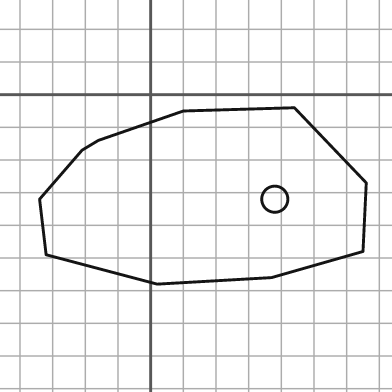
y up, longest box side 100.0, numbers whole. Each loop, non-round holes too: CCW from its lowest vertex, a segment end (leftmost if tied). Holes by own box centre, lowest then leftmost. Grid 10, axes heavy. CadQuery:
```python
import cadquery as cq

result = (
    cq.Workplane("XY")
    .moveTo(2.0, -58.0)
    .lineTo(37.0, -56.0)
    .lineTo(65.0, -48.0)
    .lineTo(66.0, -27.0)
    .lineTo(44.0, -4.0)
    .lineTo(10.0, -5.0)
    .lineTo(-16.0, -14.0)
    .lineTo(-21.0, -17.0)
    .lineTo(-34.0, -32.0)
    .lineTo(-32.0, -49.0)
    .close()
    .moveTo(38.0, -32.0)
    .circle(4.0)
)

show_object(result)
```